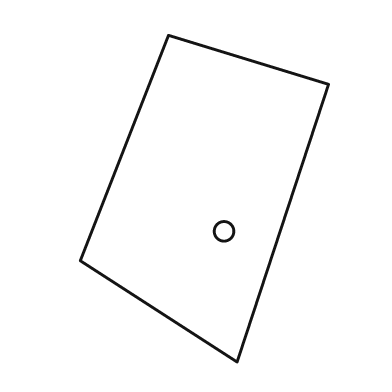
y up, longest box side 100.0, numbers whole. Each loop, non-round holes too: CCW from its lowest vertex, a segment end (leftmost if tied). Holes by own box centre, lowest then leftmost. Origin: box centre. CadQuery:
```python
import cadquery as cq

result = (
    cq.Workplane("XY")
    .moveTo(10.0, -50.0)
    .lineTo(38.0, 35.0)
    .lineTo(-11.0, 50.0)
    .lineTo(-38.0, -19.0)
    .close()
    .moveTo(6.0, -10.0)
    .circle(3.0)
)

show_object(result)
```